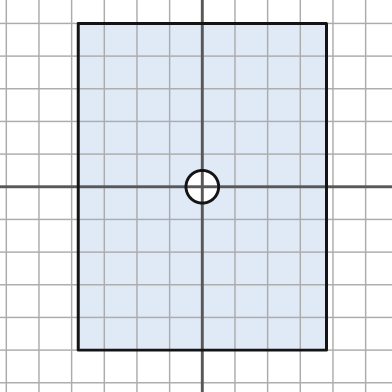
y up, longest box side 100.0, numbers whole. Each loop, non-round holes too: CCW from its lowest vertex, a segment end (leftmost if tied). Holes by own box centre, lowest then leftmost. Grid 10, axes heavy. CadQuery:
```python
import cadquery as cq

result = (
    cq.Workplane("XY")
    .moveTo(-38.0, -50.0)
    .lineTo(38.0, -50.0)
    .lineTo(38.0, 50.0)
    .lineTo(-38.0, 50.0)
    .close()
    .moveTo(0.0, 0.0)
    .circle(5.0)
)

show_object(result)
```